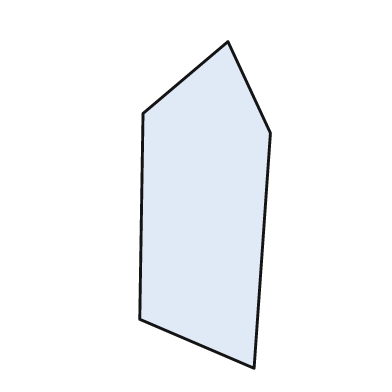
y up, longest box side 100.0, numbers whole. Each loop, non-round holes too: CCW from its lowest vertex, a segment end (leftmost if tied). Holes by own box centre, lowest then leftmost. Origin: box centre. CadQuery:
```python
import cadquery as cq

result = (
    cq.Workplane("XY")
    .moveTo(15.0, -50.0)
    .lineTo(20.0, 22.0)
    .lineTo(7.0, 50.0)
    .lineTo(-19.0, 28.0)
    .lineTo(-20.0, -35.0)
    .close()
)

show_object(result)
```